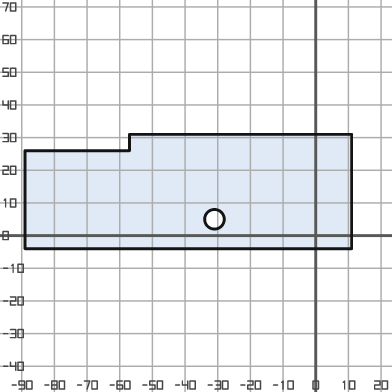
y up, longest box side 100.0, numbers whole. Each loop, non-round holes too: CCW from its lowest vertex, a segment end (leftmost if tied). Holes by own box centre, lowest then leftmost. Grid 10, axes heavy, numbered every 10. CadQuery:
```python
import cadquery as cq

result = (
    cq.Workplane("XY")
    .moveTo(-89.0, -4.0)
    .lineTo(11.0, -4.0)
    .lineTo(11.0, 31.0)
    .lineTo(-57.0, 31.0)
    .lineTo(-57.0, 26.0)
    .lineTo(-89.0, 26.0)
    .close()
    .moveTo(-31.0, 5.0)
    .circle(3.0)
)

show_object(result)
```